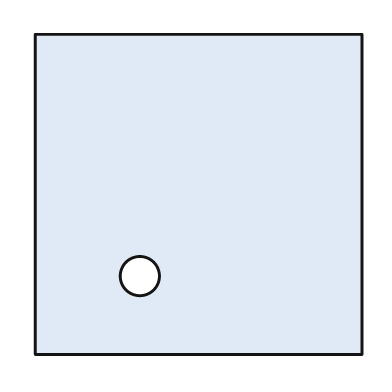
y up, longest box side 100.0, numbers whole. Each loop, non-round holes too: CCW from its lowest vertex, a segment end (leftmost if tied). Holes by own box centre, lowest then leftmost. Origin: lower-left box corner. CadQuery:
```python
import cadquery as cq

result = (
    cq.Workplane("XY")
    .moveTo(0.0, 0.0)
    .lineTo(100.0, 0.0)
    .lineTo(100.0, 98.0)
    .lineTo(0.0, 98.0)
    .close()
    .moveTo(32.0, 24.0)
    .circle(6.0)
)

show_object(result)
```